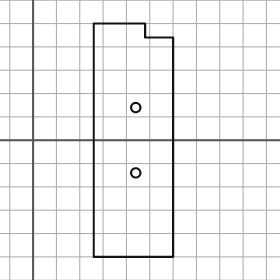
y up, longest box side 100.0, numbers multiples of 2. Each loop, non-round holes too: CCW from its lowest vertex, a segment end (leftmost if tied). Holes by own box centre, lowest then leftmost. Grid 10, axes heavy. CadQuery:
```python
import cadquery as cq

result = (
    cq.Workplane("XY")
    .moveTo(26.0, -50.0)
    .lineTo(60.0, -50.0)
    .lineTo(60.0, 44.0)
    .lineTo(48.0, 44.0)
    .lineTo(48.0, 50.0)
    .lineTo(26.0, 50.0)
    .close()
    .moveTo(44.0, -14.0)
    .circle(2.0)
    .moveTo(44.0, 14.0)
    .circle(2.0)
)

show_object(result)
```